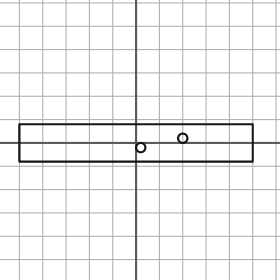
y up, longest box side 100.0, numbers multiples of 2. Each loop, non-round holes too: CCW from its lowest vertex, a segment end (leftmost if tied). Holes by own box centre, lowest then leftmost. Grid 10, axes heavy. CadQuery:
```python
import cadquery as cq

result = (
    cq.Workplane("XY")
    .moveTo(-50.0, -8.0)
    .lineTo(50.0, -8.0)
    .lineTo(50.0, 8.0)
    .lineTo(-50.0, 8.0)
    .close()
    .moveTo(2.0, -2.0)
    .circle(2.0)
    .moveTo(20.0, 2.0)
    .circle(2.0)
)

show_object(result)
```